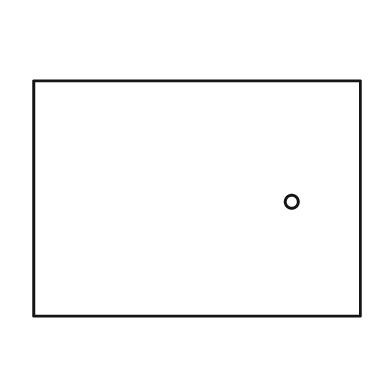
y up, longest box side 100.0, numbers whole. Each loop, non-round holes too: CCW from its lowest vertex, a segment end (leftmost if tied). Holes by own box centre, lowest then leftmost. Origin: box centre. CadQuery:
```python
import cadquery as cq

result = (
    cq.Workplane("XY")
    .moveTo(-50.0, -36.0)
    .lineTo(50.0, -36.0)
    .lineTo(50.0, 36.0)
    .lineTo(-50.0, 36.0)
    .close()
    .moveTo(29.0, -1.0)
    .circle(2.0)
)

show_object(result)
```